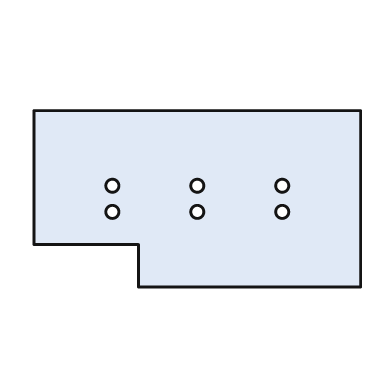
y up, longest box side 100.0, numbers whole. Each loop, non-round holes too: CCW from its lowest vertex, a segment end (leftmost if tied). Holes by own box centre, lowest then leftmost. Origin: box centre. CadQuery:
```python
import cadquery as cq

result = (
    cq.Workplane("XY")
    .moveTo(-18.0, -27.0)
    .lineTo(50.0, -27.0)
    .lineTo(50.0, 27.0)
    .lineTo(-50.0, 27.0)
    .lineTo(-50.0, -14.0)
    .lineTo(-18.0, -14.0)
    .close()
    .moveTo(-26.0, -4.0)
    .circle(2.0)
    .moveTo(0.0, -4.0)
    .circle(2.0)
    .moveTo(26.0, -4.0)
    .circle(2.0)
    .moveTo(-26.0, 4.0)
    .circle(2.0)
    .moveTo(0.0, 4.0)
    .circle(2.0)
    .moveTo(26.0, 4.0)
    .circle(2.0)
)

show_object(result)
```